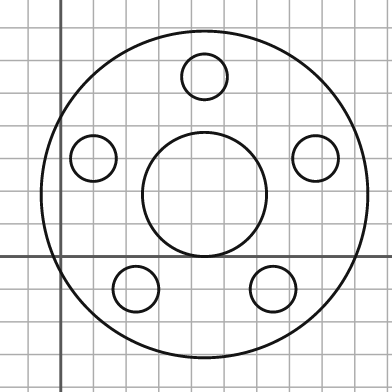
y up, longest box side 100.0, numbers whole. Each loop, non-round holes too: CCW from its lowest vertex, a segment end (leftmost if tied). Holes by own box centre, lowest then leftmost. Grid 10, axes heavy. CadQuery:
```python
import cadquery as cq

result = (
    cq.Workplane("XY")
    .moveTo(44.0, 19.0)
    .circle(50.0)
    .moveTo(23.0, -10.0)
    .circle(7.0)
    .moveTo(65.0, -10.0)
    .circle(7.0)
    .moveTo(44.0, 19.0)
    .circle(19.0)
    .moveTo(10.0, 30.0)
    .circle(7.0)
    .moveTo(78.0, 30.0)
    .circle(7.0)
    .moveTo(44.0, 55.0)
    .circle(7.0)
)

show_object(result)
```